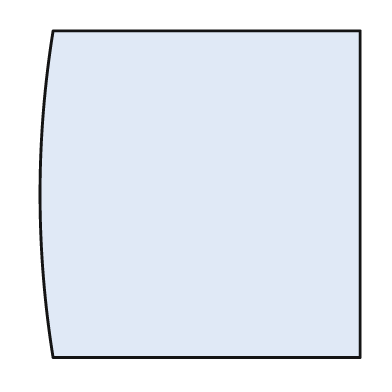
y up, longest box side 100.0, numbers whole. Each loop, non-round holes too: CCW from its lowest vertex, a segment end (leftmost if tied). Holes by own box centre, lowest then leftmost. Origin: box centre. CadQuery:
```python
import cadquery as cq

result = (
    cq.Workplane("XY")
    .moveTo(-45.0, -50.0)
    .lineTo(49.0, -50.0)
    .lineTo(49.0, 50.0)
    .lineTo(-45.0, 50.0)
    .threePointArc((-49.0, 0.0), (-45.0, -50.0))
    .close()
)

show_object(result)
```